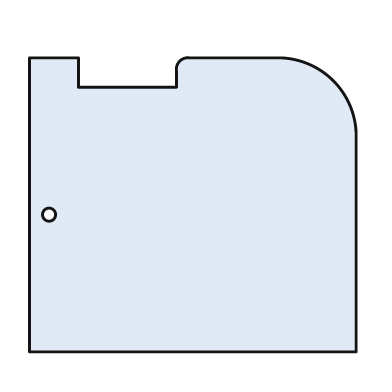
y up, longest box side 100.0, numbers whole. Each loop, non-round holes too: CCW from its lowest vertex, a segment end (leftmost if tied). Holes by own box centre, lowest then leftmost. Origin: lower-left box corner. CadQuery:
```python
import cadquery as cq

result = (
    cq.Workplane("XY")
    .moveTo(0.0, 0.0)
    .lineTo(100.0, 0.0)
    .lineTo(100.0, 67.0)
    .threePointArc((93.0, 83.0), (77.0, 90.0))
    .lineTo(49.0, 90.0)
    .threePointArc((46.0, 89.0), (45.0, 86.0))
    .lineTo(45.0, 81.0)
    .lineTo(15.0, 81.0)
    .lineTo(15.0, 90.0)
    .lineTo(0.0, 90.0)
    .close()
    .moveTo(6.0, 42.0)
    .circle(2.0)
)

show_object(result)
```